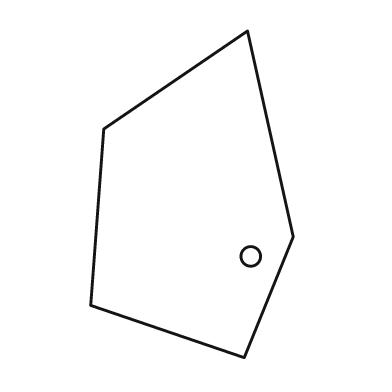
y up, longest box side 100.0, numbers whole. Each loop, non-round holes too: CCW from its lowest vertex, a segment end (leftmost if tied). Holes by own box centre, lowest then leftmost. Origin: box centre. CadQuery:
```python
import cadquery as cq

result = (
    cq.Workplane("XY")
    .moveTo(16.0, -50.0)
    .lineTo(31.0, -13.0)
    .lineTo(17.0, 50.0)
    .lineTo(-27.0, 20.0)
    .lineTo(-31.0, -34.0)
    .close()
    .moveTo(18.0, -19.0)
    .circle(3.0)
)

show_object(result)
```